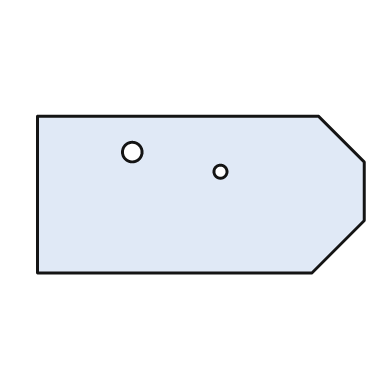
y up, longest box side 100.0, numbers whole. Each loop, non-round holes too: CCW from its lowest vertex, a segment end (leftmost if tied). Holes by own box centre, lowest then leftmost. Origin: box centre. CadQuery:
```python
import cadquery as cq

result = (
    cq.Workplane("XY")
    .moveTo(-50.0, -24.0)
    .lineTo(34.0, -24.0)
    .lineTo(50.0, -8.0)
    .lineTo(50.0, 10.0)
    .lineTo(36.0, 24.0)
    .lineTo(-50.0, 24.0)
    .close()
    .moveTo(6.0, 7.0)
    .circle(2.0)
    .moveTo(-21.0, 13.0)
    .circle(3.0)
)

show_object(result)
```